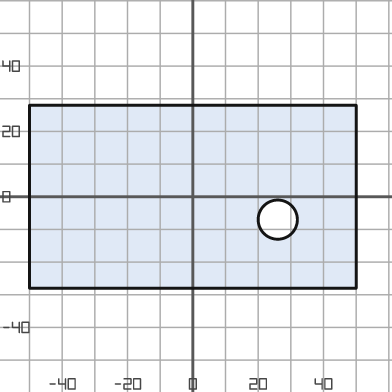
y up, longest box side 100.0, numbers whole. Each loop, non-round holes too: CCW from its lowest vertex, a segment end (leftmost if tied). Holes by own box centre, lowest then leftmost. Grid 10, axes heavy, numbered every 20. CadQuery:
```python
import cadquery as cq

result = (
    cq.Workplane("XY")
    .moveTo(-50.0, -28.0)
    .lineTo(50.0, -28.0)
    .lineTo(50.0, 28.0)
    .lineTo(-50.0, 28.0)
    .close()
    .moveTo(26.0, -7.0)
    .circle(6.0)
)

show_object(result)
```